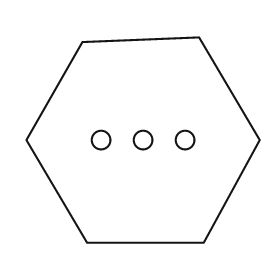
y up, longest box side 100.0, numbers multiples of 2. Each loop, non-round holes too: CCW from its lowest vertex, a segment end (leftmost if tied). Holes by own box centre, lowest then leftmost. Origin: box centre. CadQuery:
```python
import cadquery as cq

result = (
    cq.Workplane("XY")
    .moveTo(-24.0, -44.0)
    .lineTo(26.0, -44.0)
    .lineTo(50.0, 0.0)
    .lineTo(24.0, 44.0)
    .lineTo(-26.0, 42.0)
    .lineTo(-50.0, 0.0)
    .close()
    .moveTo(-18.0, 0.0)
    .circle(4.0)
    .moveTo(0.0, 0.0)
    .circle(4.0)
    .moveTo(18.0, 0.0)
    .circle(4.0)
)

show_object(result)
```